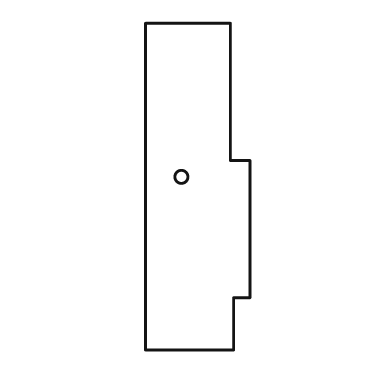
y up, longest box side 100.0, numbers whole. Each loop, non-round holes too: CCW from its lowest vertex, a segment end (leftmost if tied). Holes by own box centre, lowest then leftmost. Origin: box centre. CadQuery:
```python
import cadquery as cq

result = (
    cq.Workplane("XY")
    .moveTo(-16.0, -50.0)
    .lineTo(11.0, -50.0)
    .lineTo(11.0, -34.0)
    .lineTo(16.0, -34.0)
    .lineTo(16.0, 8.0)
    .lineTo(10.0, 8.0)
    .lineTo(10.0, 50.0)
    .lineTo(-16.0, 50.0)
    .close()
    .moveTo(-5.0, 3.0)
    .circle(2.0)
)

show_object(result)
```